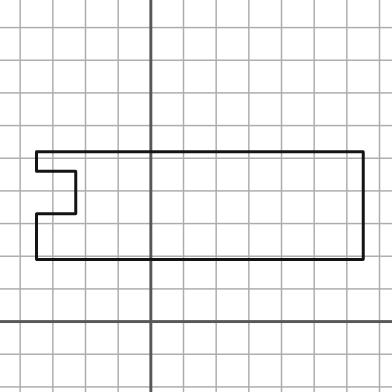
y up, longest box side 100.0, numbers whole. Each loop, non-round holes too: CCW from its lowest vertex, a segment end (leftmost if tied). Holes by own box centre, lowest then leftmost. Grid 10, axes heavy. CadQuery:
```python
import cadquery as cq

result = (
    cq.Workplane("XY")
    .moveTo(-35.0, 19.0)
    .lineTo(65.0, 19.0)
    .lineTo(65.0, 52.0)
    .lineTo(-35.0, 52.0)
    .lineTo(-35.0, 46.0)
    .lineTo(-23.0, 46.0)
    .lineTo(-23.0, 33.0)
    .lineTo(-35.0, 33.0)
    .close()
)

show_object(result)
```